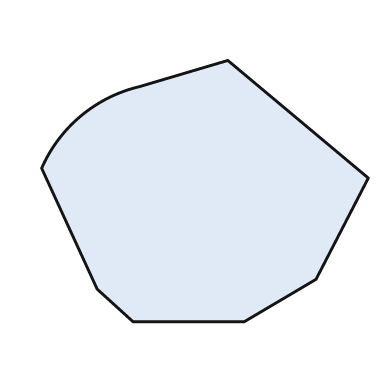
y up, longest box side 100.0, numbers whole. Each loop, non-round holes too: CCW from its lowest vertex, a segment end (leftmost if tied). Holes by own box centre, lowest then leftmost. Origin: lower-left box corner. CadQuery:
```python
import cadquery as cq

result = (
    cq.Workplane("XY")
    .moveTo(28.0, 0.0)
    .lineTo(62.0, 0.0)
    .lineTo(84.0, 13.0)
    .lineTo(100.0, 44.0)
    .lineTo(57.0, 80.0)
    .lineTo(30.0, 72.0)
    .threePointArc((12.0, 63.0), (0.0, 47.0))
    .lineTo(17.0, 10.0)
    .close()
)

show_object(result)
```